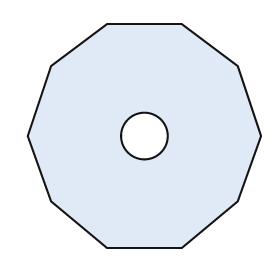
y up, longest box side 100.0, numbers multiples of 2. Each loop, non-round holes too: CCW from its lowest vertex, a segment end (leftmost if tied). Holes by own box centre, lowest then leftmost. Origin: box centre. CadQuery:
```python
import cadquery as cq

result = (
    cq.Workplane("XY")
    .moveTo(-16.0, -48.0)
    .lineTo(16.0, -48.0)
    .lineTo(40.0, -28.0)
    .lineTo(50.0, 0.0)
    .lineTo(40.0, 30.0)
    .lineTo(16.0, 48.0)
    .lineTo(-16.0, 48.0)
    .lineTo(-40.0, 30.0)
    .lineTo(-50.0, 0.0)
    .lineTo(-40.0, -28.0)
    .close()
    .moveTo(0.0, 0.0)
    .circle(10.0)
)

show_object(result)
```